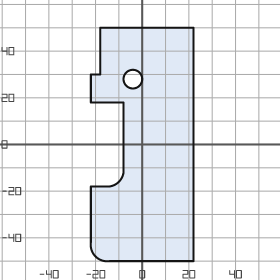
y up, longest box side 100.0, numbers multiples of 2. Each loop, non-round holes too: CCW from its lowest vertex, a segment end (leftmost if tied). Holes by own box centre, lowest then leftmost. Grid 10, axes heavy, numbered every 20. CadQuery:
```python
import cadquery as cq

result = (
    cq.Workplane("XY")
    .moveTo(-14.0, -50.0)
    .lineTo(22.0, -50.0)
    .lineTo(22.0, 50.0)
    .lineTo(-18.0, 50.0)
    .lineTo(-18.0, 30.0)
    .lineTo(-22.0, 30.0)
    .lineTo(-22.0, 18.0)
    .lineTo(-8.0, 18.0)
    .lineTo(-8.0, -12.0)
    .threePointArc((-10.0, -16.0), (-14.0, -18.0))
    .lineTo(-22.0, -18.0)
    .lineTo(-22.0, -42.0)
    .threePointArc((-20.0, -48.0), (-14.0, -50.0))
    .close()
    .moveTo(-4.0, 28.0)
    .circle(4.0)
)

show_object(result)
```